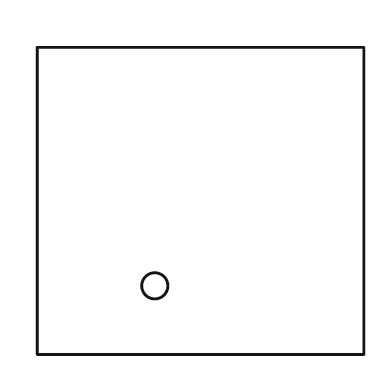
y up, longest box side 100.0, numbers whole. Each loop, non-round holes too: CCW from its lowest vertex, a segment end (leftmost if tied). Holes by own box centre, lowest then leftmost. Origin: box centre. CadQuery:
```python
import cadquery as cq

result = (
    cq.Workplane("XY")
    .moveTo(-50.0, -47.0)
    .lineTo(50.0, -47.0)
    .lineTo(50.0, 47.0)
    .lineTo(-50.0, 47.0)
    .close()
    .moveTo(-14.0, -26.0)
    .circle(4.0)
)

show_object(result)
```